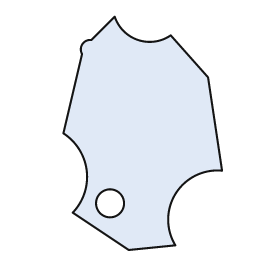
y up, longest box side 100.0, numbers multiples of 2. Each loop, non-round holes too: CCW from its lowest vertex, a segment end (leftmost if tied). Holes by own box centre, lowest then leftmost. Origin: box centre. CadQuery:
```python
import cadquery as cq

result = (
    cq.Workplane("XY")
    .moveTo(-6.0, -50.0)
    .lineTo(14.0, -48.0)
    .threePointArc((14.0, -26.0), (34.0, -16.0))
    .lineTo(28.0, 24.0)
    .lineTo(12.0, 42.0)
    .threePointArc((-2.0, 40.0), (-12.0, 50.0))
    .lineTo(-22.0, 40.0)
    .threePointArc((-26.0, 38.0), (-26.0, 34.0))
    .lineTo(-34.0, 0.0)
    .threePointArc((-24.0, -16.0), (-30.0, -34.0))
    .close()
    .moveTo(-14.0, -30.0)
    .circle(6.0)
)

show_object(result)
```